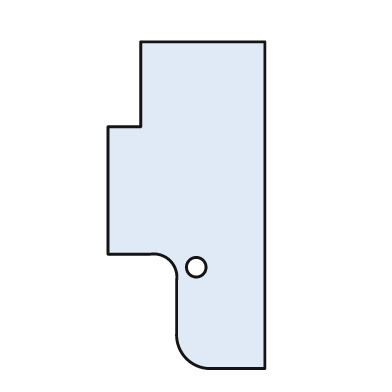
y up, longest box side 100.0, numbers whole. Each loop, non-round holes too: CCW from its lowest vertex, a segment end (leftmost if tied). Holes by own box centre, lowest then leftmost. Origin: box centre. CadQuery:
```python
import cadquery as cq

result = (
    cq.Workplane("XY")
    .moveTo(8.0, -50.0)
    .lineTo(24.0, -50.0)
    .lineTo(24.0, 50.0)
    .lineTo(-14.0, 50.0)
    .lineTo(-14.0, 24.0)
    .lineTo(-24.0, 24.0)
    .lineTo(-24.0, -15.0)
    .lineTo(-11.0, -15.0)
    .threePointArc((-5.0, -17.0), (-3.0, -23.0))
    .lineTo(-3.0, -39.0)
    .threePointArc((0.0, -47.0), (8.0, -50.0))
    .close()
    .moveTo(3.0, -19.0)
    .circle(3.0)
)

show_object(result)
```